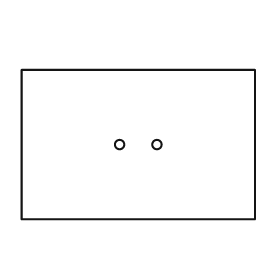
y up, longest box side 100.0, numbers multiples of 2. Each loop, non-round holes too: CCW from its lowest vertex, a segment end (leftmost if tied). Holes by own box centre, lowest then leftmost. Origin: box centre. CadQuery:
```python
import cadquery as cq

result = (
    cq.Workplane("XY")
    .moveTo(-50.0, -32.0)
    .lineTo(50.0, -32.0)
    .lineTo(50.0, 32.0)
    .lineTo(-50.0, 32.0)
    .close()
    .moveTo(-8.0, 0.0)
    .circle(2.0)
    .moveTo(8.0, 0.0)
    .circle(2.0)
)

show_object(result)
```